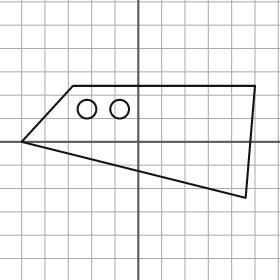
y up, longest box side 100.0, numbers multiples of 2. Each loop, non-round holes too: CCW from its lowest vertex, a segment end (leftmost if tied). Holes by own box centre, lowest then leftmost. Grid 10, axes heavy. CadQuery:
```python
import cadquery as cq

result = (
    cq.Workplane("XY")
    .moveTo(46.0, -24.0)
    .lineTo(50.0, 24.0)
    .lineTo(-28.0, 24.0)
    .lineTo(-50.0, 0.0)
    .close()
    .moveTo(-22.0, 14.0)
    .circle(4.0)
    .moveTo(-8.0, 14.0)
    .circle(4.0)
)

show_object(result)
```